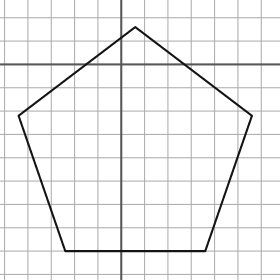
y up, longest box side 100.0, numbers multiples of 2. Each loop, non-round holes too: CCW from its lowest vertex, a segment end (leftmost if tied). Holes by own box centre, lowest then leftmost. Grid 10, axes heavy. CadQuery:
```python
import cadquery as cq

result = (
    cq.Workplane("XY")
    .moveTo(-24.0, -80.0)
    .lineTo(36.0, -80.0)
    .lineTo(56.0, -22.0)
    .lineTo(6.0, 16.0)
    .lineTo(-44.0, -22.0)
    .close()
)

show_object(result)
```